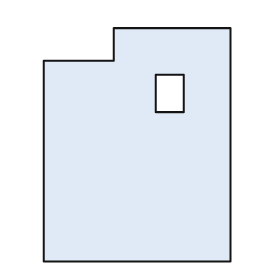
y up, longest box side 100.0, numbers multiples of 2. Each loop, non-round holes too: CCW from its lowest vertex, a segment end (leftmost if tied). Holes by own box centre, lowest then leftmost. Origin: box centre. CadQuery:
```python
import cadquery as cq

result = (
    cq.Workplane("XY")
    .moveTo(-40.0, -50.0)
    .lineTo(40.0, -50.0)
    .lineTo(40.0, 50.0)
    .lineTo(-10.0, 50.0)
    .lineTo(-10.0, 36.0)
    .lineTo(-40.0, 36.0)
    .close()
    .moveTo(8.0, 14.0)
    .lineTo(20.0, 14.0)
    .lineTo(20.0, 30.0)
    .lineTo(8.0, 30.0)
    .close()
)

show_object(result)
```